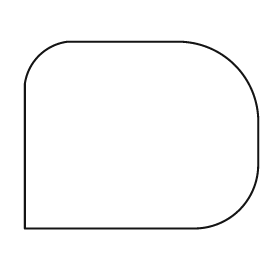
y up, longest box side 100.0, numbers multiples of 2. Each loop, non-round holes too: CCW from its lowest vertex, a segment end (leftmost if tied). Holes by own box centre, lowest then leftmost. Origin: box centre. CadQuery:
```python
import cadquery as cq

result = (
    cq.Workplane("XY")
    .moveTo(-50.0, -40.0)
    .lineTo(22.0, -40.0)
    .threePointArc((42.0, -32.0), (50.0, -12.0))
    .lineTo(50.0, 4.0)
    .threePointArc((40.0, 30.0), (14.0, 40.0))
    .lineTo(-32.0, 40.0)
    .threePointArc((-44.0, 34.0), (-50.0, 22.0))
    .close()
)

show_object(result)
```